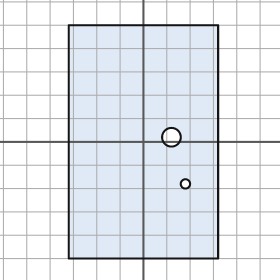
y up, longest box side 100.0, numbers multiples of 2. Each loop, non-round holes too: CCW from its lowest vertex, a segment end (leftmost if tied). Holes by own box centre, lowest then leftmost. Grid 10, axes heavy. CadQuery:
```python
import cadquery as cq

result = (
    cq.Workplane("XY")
    .moveTo(-32.0, -50.0)
    .lineTo(32.0, -50.0)
    .lineTo(32.0, 50.0)
    .lineTo(-32.0, 50.0)
    .close()
    .moveTo(18.0, -18.0)
    .circle(2.0)
    .moveTo(12.0, 2.0)
    .circle(4.0)
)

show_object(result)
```